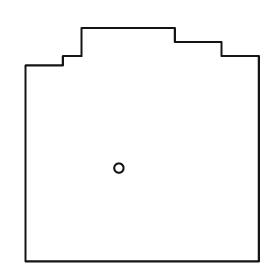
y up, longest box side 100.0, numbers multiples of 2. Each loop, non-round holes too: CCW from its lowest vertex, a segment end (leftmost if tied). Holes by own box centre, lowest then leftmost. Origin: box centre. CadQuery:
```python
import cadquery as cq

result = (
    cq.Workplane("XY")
    .moveTo(-50.0, -50.0)
    .lineTo(50.0, -50.0)
    .lineTo(50.0, 38.0)
    .lineTo(34.0, 38.0)
    .lineTo(34.0, 44.0)
    .lineTo(14.0, 44.0)
    .lineTo(14.0, 50.0)
    .lineTo(-26.0, 50.0)
    .lineTo(-26.0, 38.0)
    .lineTo(-34.0, 38.0)
    .lineTo(-34.0, 34.0)
    .lineTo(-50.0, 34.0)
    .close()
    .moveTo(-10.0, -10.0)
    .circle(2.0)
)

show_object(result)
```